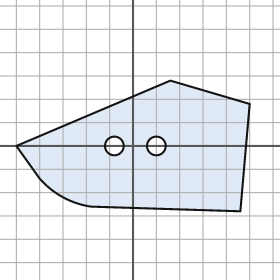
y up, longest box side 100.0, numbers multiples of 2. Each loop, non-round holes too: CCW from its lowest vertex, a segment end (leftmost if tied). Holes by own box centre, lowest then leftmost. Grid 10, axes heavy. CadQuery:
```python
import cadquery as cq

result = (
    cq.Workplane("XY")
    .moveTo(46.0, -28.0)
    .lineTo(50.0, 18.0)
    .lineTo(16.0, 28.0)
    .lineTo(-50.0, 0.0)
    .lineTo(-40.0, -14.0)
    .threePointArc((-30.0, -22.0), (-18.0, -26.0))
    .close()
    .moveTo(-8.0, 0.0)
    .circle(4.0)
    .moveTo(10.0, 0.0)
    .circle(4.0)
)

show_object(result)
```